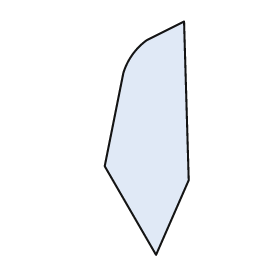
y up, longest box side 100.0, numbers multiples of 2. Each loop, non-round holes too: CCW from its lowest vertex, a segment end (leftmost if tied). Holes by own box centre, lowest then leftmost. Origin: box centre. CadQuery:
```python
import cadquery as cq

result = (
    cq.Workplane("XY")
    .moveTo(4.0, -50.0)
    .lineTo(18.0, -18.0)
    .lineTo(16.0, 50.0)
    .lineTo(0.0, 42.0)
    .threePointArc((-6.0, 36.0), (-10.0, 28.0))
    .lineTo(-18.0, -12.0)
    .close()
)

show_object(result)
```